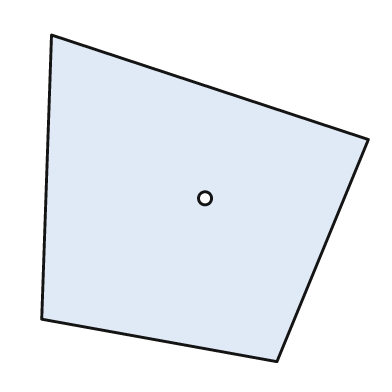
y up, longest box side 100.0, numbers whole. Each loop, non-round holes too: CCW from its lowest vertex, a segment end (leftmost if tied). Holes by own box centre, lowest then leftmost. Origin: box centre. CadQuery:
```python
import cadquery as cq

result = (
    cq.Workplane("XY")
    .moveTo(22.0, -50.0)
    .lineTo(50.0, 18.0)
    .lineTo(-47.0, 50.0)
    .lineTo(-50.0, -37.0)
    .close()
    .moveTo(0.0, 0.0)
    .circle(2.0)
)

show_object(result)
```